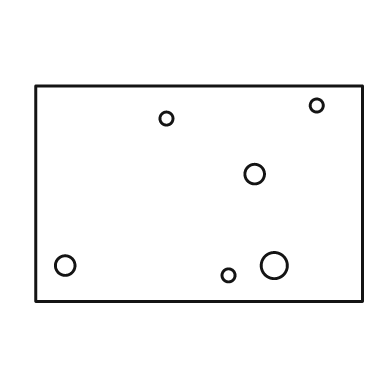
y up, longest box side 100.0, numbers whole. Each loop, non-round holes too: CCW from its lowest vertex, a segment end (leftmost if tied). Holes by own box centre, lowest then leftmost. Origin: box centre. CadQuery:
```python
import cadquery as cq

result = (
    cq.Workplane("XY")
    .moveTo(-50.0, -33.0)
    .lineTo(50.0, -33.0)
    .lineTo(50.0, 33.0)
    .lineTo(-50.0, 33.0)
    .close()
    .moveTo(9.0, -25.0)
    .circle(2.0)
    .moveTo(-41.0, -22.0)
    .circle(3.0)
    .moveTo(23.0, -22.0)
    .circle(4.0)
    .moveTo(17.0, 6.0)
    .circle(3.0)
    .moveTo(-10.0, 23.0)
    .circle(2.0)
    .moveTo(36.0, 27.0)
    .circle(2.0)
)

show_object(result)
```